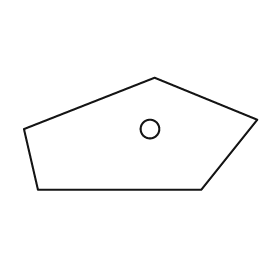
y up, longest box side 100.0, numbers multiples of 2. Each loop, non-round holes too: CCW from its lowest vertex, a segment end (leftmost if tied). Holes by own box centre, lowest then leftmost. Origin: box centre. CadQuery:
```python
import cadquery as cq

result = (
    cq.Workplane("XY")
    .moveTo(-44.0, -24.0)
    .lineTo(26.0, -24.0)
    .lineTo(50.0, 6.0)
    .lineTo(6.0, 24.0)
    .lineTo(-50.0, 2.0)
    .close()
    .moveTo(4.0, 2.0)
    .circle(4.0)
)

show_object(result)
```